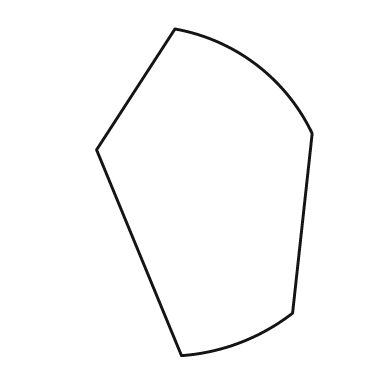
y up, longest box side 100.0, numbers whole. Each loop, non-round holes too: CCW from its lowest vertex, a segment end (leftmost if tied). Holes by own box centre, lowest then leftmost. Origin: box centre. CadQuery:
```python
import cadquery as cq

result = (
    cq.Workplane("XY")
    .moveTo(-7.0, -50.0)
    .threePointArc((11.0, -46.0), (27.0, -37.0))
    .lineTo(33.0, 18.0)
    .threePointArc((16.0, 39.0), (-9.0, 50.0))
    .lineTo(-33.0, 13.0)
    .close()
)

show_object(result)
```